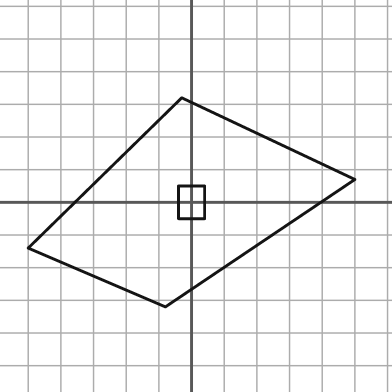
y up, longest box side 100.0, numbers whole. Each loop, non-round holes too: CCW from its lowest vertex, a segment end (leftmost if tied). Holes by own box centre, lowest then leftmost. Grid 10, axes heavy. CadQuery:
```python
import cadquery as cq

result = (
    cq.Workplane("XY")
    .moveTo(-8.0, -32.0)
    .lineTo(50.0, 7.0)
    .lineTo(-3.0, 32.0)
    .lineTo(-50.0, -14.0)
    .close()
    .moveTo(-4.0, -5.0)
    .lineTo(4.0, -5.0)
    .lineTo(4.0, 5.0)
    .lineTo(-4.0, 5.0)
    .close()
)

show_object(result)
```